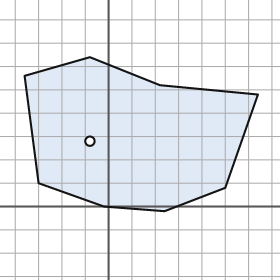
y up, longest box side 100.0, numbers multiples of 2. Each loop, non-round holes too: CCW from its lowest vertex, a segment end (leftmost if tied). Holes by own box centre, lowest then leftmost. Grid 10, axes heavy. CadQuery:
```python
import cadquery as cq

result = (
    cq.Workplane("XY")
    .moveTo(24.0, -2.0)
    .lineTo(50.0, 8.0)
    .lineTo(64.0, 48.0)
    .lineTo(22.0, 52.0)
    .lineTo(-8.0, 64.0)
    .lineTo(-36.0, 56.0)
    .lineTo(-30.0, 10.0)
    .lineTo(-2.0, 0.0)
    .close()
    .moveTo(-8.0, 28.0)
    .circle(2.0)
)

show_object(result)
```